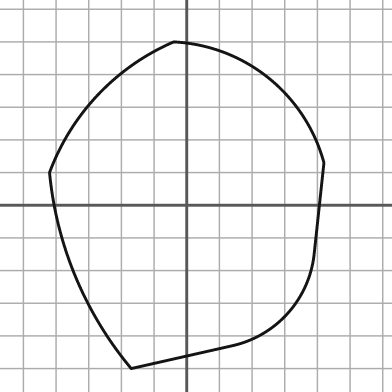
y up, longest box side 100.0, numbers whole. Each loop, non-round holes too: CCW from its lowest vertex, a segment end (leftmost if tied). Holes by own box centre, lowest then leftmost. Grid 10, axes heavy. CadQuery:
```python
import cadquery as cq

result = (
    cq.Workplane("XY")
    .moveTo(-17.0, -50.0)
    .lineTo(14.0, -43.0)
    .threePointArc((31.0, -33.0), (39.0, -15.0))
    .lineTo(42.0, 13.0)
    .threePointArc((25.0, 39.0), (-4.0, 50.0))
    .threePointArc((-27.0, 34.0), (-42.0, 10.0))
    .threePointArc((-34.0, -22.0), (-17.0, -50.0))
    .close()
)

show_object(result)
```